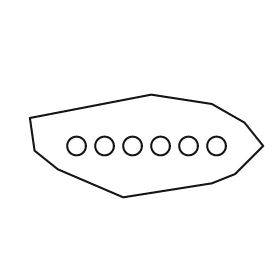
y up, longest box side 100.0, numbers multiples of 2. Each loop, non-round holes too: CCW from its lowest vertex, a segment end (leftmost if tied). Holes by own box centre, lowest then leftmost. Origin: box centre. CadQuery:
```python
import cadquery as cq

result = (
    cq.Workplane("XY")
    .moveTo(-10.0, -22.0)
    .lineTo(28.0, -16.0)
    .lineTo(38.0, -12.0)
    .lineTo(50.0, 0.0)
    .lineTo(42.0, 10.0)
    .lineTo(28.0, 18.0)
    .lineTo(2.0, 22.0)
    .lineTo(-50.0, 12.0)
    .lineTo(-48.0, -2.0)
    .lineTo(-38.0, -10.0)
    .close()
    .moveTo(-30.0, 0.0)
    .circle(4.0)
    .moveTo(-18.0, 0.0)
    .circle(4.0)
    .moveTo(-6.0, 0.0)
    .circle(4.0)
    .moveTo(6.0, 0.0)
    .circle(4.0)
    .moveTo(18.0, 0.0)
    .circle(4.0)
    .moveTo(30.0, 0.0)
    .circle(4.0)
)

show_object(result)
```